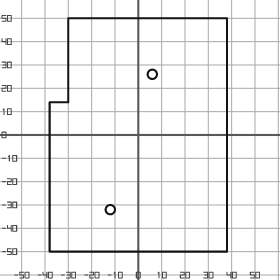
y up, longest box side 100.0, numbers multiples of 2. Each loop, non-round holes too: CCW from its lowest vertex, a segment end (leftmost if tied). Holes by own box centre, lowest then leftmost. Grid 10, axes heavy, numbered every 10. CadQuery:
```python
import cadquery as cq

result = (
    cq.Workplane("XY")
    .moveTo(-38.0, -50.0)
    .lineTo(38.0, -50.0)
    .lineTo(38.0, 50.0)
    .lineTo(-30.0, 50.0)
    .lineTo(-30.0, 14.0)
    .lineTo(-38.0, 14.0)
    .close()
    .moveTo(-12.0, -32.0)
    .circle(2.0)
    .moveTo(6.0, 26.0)
    .circle(2.0)
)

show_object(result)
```